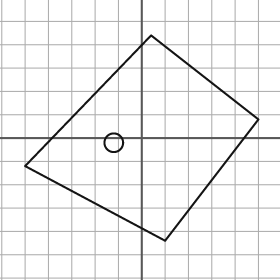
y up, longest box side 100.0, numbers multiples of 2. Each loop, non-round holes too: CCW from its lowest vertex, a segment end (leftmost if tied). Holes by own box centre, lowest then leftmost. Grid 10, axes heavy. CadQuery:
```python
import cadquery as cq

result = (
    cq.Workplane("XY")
    .moveTo(10.0, -44.0)
    .lineTo(50.0, 8.0)
    .lineTo(4.0, 44.0)
    .lineTo(-50.0, -12.0)
    .close()
    .moveTo(-12.0, -2.0)
    .circle(4.0)
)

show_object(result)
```